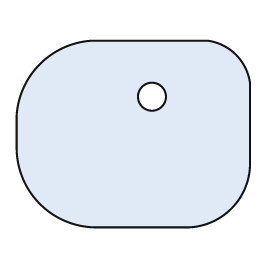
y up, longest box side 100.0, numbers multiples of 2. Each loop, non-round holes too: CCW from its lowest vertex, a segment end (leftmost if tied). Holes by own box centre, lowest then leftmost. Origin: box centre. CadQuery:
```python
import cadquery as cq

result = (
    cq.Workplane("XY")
    .moveTo(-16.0, -40.0)
    .lineTo(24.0, -40.0)
    .threePointArc((42.0, -32.0), (50.0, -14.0))
    .lineTo(50.0, 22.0)
    .threePointArc((44.0, 34.0), (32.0, 40.0))
    .lineTo(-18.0, 40.0)
    .threePointArc((-40.0, 30.0), (-50.0, 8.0))
    .lineTo(-50.0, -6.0)
    .threePointArc((-40.0, -30.0), (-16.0, -40.0))
    .close()
    .moveTo(8.0, 16.0)
    .circle(6.0)
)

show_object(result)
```